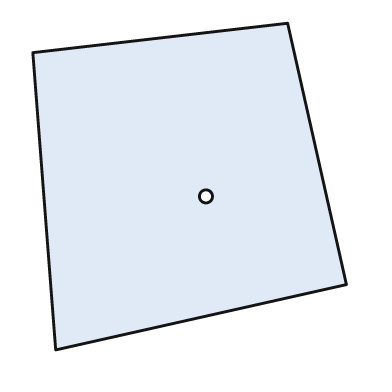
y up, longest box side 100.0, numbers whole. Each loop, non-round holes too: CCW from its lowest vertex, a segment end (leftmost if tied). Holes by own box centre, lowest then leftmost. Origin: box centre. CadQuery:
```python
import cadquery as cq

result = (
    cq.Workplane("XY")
    .moveTo(-41.0, -50.0)
    .lineTo(48.0, -30.0)
    .lineTo(30.0, 50.0)
    .lineTo(-48.0, 41.0)
    .close()
    .moveTo(5.0, -3.0)
    .circle(2.0)
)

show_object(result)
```